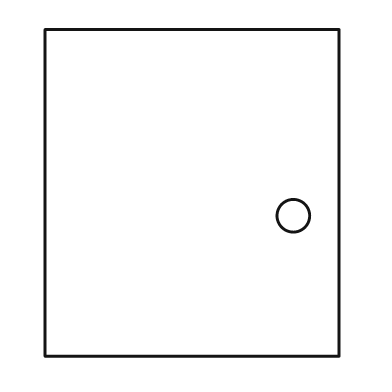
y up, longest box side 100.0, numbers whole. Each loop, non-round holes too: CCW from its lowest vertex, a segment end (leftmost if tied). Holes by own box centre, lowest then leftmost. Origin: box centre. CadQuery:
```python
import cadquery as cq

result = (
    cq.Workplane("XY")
    .moveTo(-45.0, -50.0)
    .lineTo(45.0, -50.0)
    .lineTo(45.0, 50.0)
    .lineTo(-45.0, 50.0)
    .close()
    .moveTo(31.0, -7.0)
    .circle(5.0)
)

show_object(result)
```